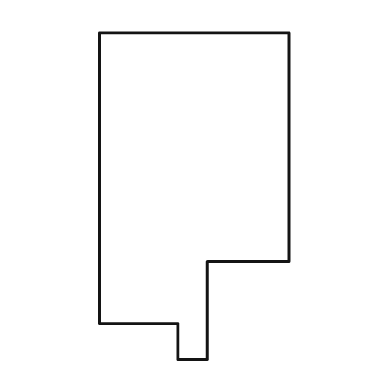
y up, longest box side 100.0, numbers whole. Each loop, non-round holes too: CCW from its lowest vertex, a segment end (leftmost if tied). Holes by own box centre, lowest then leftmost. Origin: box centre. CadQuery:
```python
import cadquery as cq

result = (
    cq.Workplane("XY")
    .moveTo(-5.0, -50.0)
    .lineTo(4.0, -50.0)
    .lineTo(4.0, -20.0)
    .lineTo(29.0, -20.0)
    .lineTo(29.0, 50.0)
    .lineTo(-29.0, 50.0)
    .lineTo(-29.0, -39.0)
    .lineTo(-5.0, -39.0)
    .close()
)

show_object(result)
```